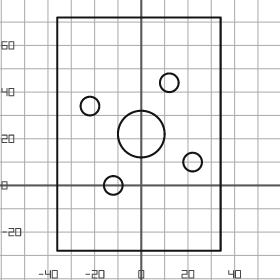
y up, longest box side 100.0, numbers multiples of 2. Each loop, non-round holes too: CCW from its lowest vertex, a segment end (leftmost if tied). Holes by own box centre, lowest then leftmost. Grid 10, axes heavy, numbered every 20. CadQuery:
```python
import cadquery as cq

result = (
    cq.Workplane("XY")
    .moveTo(-36.0, -28.0)
    .lineTo(34.0, -28.0)
    .lineTo(34.0, 72.0)
    .lineTo(-36.0, 72.0)
    .close()
    .moveTo(-12.0, 0.0)
    .circle(4.0)
    .moveTo(22.0, 10.0)
    .circle(4.0)
    .moveTo(0.0, 22.0)
    .circle(10.0)
    .moveTo(-22.0, 34.0)
    .circle(4.0)
    .moveTo(12.0, 44.0)
    .circle(4.0)
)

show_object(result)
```